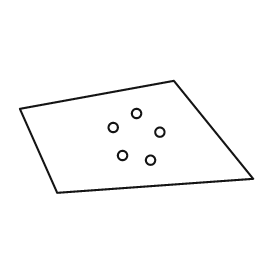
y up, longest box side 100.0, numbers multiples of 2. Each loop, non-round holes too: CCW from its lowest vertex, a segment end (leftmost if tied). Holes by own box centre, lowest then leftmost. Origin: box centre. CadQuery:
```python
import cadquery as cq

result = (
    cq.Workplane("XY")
    .moveTo(-34.0, -24.0)
    .lineTo(50.0, -18.0)
    .lineTo(16.0, 24.0)
    .lineTo(-50.0, 12.0)
    .close()
    .moveTo(6.0, -10.0)
    .circle(2.0)
    .moveTo(-6.0, -8.0)
    .circle(2.0)
    .moveTo(10.0, 2.0)
    .circle(2.0)
    .moveTo(-10.0, 4.0)
    .circle(2.0)
    .moveTo(0.0, 10.0)
    .circle(2.0)
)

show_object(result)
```